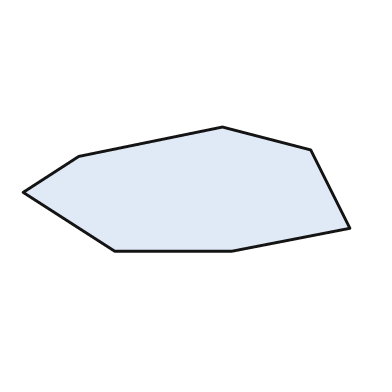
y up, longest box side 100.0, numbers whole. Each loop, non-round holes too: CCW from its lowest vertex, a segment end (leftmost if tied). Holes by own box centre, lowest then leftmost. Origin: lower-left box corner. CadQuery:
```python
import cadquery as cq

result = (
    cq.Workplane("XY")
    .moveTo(28.0, 0.0)
    .lineTo(64.0, 0.0)
    .lineTo(100.0, 7.0)
    .lineTo(88.0, 31.0)
    .lineTo(61.0, 38.0)
    .lineTo(17.0, 29.0)
    .lineTo(0.0, 18.0)
    .close()
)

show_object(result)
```